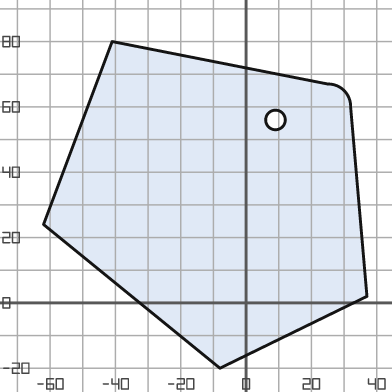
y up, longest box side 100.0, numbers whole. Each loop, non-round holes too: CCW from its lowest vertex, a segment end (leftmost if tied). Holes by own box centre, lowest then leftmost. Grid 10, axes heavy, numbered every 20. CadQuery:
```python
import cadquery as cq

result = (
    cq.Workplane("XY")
    .moveTo(-8.0, -20.0)
    .lineTo(37.0, 2.0)
    .lineTo(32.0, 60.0)
    .threePointArc((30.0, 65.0), (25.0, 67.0))
    .lineTo(-41.0, 80.0)
    .lineTo(-62.0, 24.0)
    .close()
    .moveTo(9.0, 56.0)
    .circle(3.0)
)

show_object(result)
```